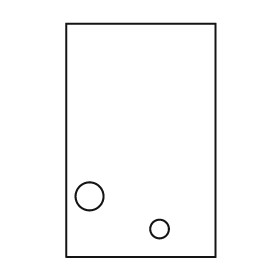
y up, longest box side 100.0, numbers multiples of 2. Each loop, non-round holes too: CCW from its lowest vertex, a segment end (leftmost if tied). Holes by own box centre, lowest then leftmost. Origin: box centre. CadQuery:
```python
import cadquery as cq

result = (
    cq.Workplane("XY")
    .moveTo(-32.0, -50.0)
    .lineTo(32.0, -50.0)
    .lineTo(32.0, 50.0)
    .lineTo(-32.0, 50.0)
    .close()
    .moveTo(8.0, -38.0)
    .circle(4.0)
    .moveTo(-22.0, -24.0)
    .circle(6.0)
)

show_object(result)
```